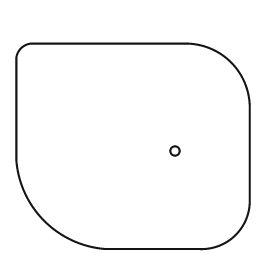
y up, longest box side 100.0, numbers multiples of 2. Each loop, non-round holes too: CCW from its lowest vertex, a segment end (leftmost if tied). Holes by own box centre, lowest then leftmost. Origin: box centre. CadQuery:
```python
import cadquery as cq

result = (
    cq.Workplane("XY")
    .moveTo(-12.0, -44.0)
    .lineTo(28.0, -44.0)
    .threePointArc((44.0, -38.0), (50.0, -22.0))
    .lineTo(50.0, 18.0)
    .threePointArc((42.0, 36.0), (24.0, 44.0))
    .lineTo(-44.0, 44.0)
    .threePointArc((-48.0, 42.0), (-50.0, 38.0))
    .lineTo(-50.0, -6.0)
    .threePointArc((-38.0, -32.0), (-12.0, -44.0))
    .close()
    .moveTo(18.0, -2.0)
    .circle(2.0)
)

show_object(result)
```